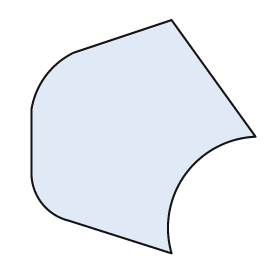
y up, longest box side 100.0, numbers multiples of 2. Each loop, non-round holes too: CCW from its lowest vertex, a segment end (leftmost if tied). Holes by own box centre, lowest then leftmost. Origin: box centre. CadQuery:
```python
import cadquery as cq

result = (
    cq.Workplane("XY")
    .moveTo(12.0, -50.0)
    .threePointArc((18.0, -16.0), (48.0, 0.0))
    .lineTo(12.0, 50.0)
    .lineTo(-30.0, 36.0)
    .threePointArc((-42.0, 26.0), (-48.0, 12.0))
    .lineTo(-48.0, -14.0)
    .threePointArc((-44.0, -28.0), (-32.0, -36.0))
    .close()
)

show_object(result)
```